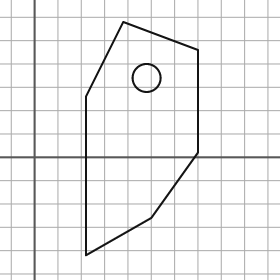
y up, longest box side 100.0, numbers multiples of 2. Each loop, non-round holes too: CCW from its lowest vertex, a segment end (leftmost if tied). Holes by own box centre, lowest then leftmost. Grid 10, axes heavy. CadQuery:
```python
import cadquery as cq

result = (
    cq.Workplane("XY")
    .moveTo(22.0, -42.0)
    .lineTo(50.0, -26.0)
    .lineTo(70.0, 2.0)
    .lineTo(70.0, 46.0)
    .lineTo(38.0, 58.0)
    .lineTo(22.0, 26.0)
    .close()
    .moveTo(48.0, 34.0)
    .circle(6.0)
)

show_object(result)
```